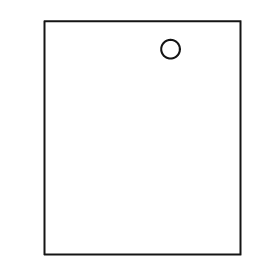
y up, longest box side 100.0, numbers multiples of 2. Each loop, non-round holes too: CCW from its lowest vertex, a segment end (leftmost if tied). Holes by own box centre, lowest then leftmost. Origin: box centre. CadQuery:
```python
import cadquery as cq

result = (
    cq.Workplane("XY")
    .moveTo(-42.0, -50.0)
    .lineTo(42.0, -50.0)
    .lineTo(42.0, 50.0)
    .lineTo(-42.0, 50.0)
    .close()
    .moveTo(12.0, 38.0)
    .circle(4.0)
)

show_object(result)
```